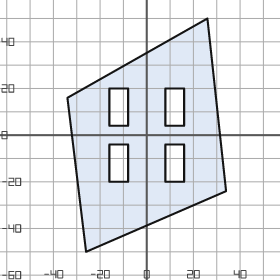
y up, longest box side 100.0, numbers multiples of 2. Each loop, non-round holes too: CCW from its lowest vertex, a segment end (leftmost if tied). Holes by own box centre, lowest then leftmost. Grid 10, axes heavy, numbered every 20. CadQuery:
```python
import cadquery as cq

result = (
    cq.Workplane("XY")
    .moveTo(-26.0, -50.0)
    .lineTo(34.0, -24.0)
    .lineTo(26.0, 50.0)
    .lineTo(-34.0, 16.0)
    .close()
    .moveTo(-16.0, -20.0)
    .lineTo(-8.0, -20.0)
    .lineTo(-8.0, -4.0)
    .lineTo(-16.0, -4.0)
    .close()
    .moveTo(8.0, -20.0)
    .lineTo(16.0, -20.0)
    .lineTo(16.0, -4.0)
    .lineTo(8.0, -4.0)
    .close()
    .moveTo(-16.0, 4.0)
    .lineTo(-8.0, 4.0)
    .lineTo(-8.0, 20.0)
    .lineTo(-16.0, 20.0)
    .close()
    .moveTo(8.0, 4.0)
    .lineTo(16.0, 4.0)
    .lineTo(16.0, 20.0)
    .lineTo(8.0, 20.0)
    .close()
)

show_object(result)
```